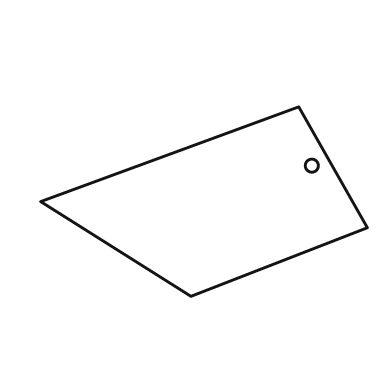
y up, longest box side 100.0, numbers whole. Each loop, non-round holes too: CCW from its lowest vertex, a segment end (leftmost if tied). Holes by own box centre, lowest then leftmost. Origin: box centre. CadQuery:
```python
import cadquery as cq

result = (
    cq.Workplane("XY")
    .moveTo(-4.0, -29.0)
    .lineTo(50.0, -8.0)
    .lineTo(29.0, 29.0)
    .lineTo(-50.0, 0.0)
    .close()
    .moveTo(33.0, 11.0)
    .circle(2.0)
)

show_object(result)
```